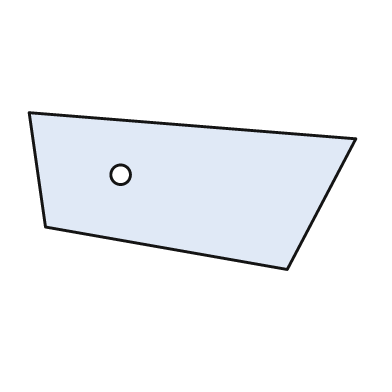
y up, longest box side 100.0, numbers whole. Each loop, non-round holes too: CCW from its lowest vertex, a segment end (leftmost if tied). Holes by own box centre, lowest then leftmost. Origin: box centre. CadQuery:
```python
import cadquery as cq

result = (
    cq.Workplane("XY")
    .moveTo(29.0, -24.0)
    .lineTo(50.0, 16.0)
    .lineTo(-50.0, 24.0)
    .lineTo(-45.0, -11.0)
    .close()
    .moveTo(-22.0, 5.0)
    .circle(3.0)
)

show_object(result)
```